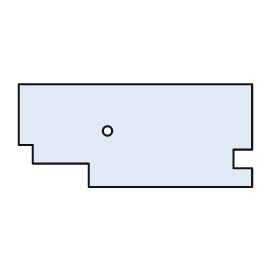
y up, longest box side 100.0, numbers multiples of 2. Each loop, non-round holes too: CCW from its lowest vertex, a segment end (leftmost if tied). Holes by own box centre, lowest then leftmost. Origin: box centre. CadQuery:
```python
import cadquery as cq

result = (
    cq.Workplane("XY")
    .moveTo(-20.0, -22.0)
    .lineTo(50.0, -22.0)
    .lineTo(50.0, -14.0)
    .lineTo(42.0, -14.0)
    .lineTo(42.0, -6.0)
    .lineTo(50.0, -6.0)
    .lineTo(50.0, 22.0)
    .lineTo(-50.0, 22.0)
    .lineTo(-50.0, -4.0)
    .lineTo(-44.0, -4.0)
    .lineTo(-44.0, -12.0)
    .lineTo(-20.0, -12.0)
    .close()
    .moveTo(-12.0, 2.0)
    .circle(2.0)
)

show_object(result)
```